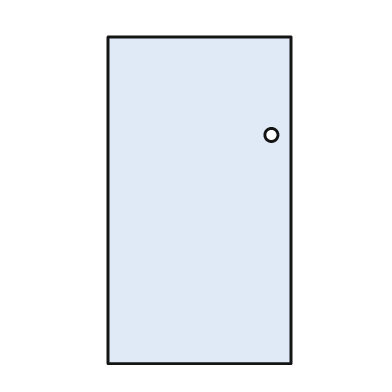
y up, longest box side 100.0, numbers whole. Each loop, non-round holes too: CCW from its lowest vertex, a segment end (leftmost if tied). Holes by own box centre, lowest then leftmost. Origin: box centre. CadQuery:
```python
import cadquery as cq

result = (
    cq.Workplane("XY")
    .moveTo(-28.0, -50.0)
    .lineTo(28.0, -50.0)
    .lineTo(28.0, 50.0)
    .lineTo(-28.0, 50.0)
    .close()
    .moveTo(22.0, 20.0)
    .circle(2.0)
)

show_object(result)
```